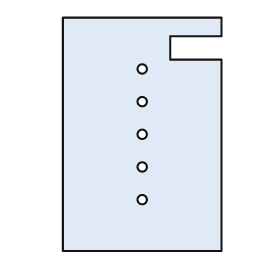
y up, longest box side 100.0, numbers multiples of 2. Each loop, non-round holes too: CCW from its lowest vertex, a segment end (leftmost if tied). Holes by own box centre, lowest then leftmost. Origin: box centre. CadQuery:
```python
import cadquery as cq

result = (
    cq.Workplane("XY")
    .moveTo(-34.0, -50.0)
    .lineTo(34.0, -50.0)
    .lineTo(34.0, 32.0)
    .lineTo(12.0, 32.0)
    .lineTo(12.0, 42.0)
    .lineTo(34.0, 42.0)
    .lineTo(34.0, 50.0)
    .lineTo(-34.0, 50.0)
    .close()
    .moveTo(0.0, -28.0)
    .circle(2.0)
    .moveTo(0.0, -14.0)
    .circle(2.0)
    .moveTo(0.0, 0.0)
    .circle(2.0)
    .moveTo(0.0, 14.0)
    .circle(2.0)
    .moveTo(0.0, 28.0)
    .circle(2.0)
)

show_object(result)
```